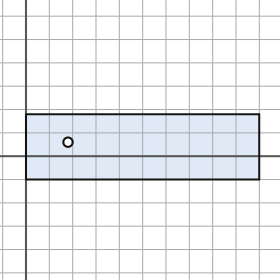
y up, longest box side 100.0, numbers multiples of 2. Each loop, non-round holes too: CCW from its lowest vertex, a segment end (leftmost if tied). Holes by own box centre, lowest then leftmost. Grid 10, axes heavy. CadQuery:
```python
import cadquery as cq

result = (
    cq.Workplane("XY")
    .moveTo(0.0, -10.0)
    .lineTo(100.0, -10.0)
    .lineTo(100.0, 18.0)
    .lineTo(0.0, 18.0)
    .close()
    .moveTo(18.0, 6.0)
    .circle(2.0)
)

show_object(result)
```